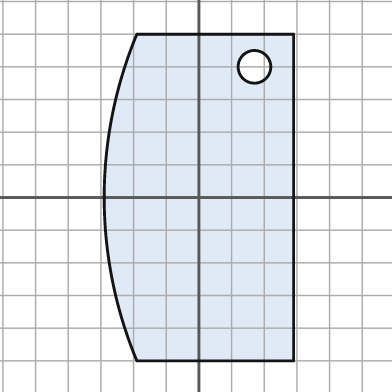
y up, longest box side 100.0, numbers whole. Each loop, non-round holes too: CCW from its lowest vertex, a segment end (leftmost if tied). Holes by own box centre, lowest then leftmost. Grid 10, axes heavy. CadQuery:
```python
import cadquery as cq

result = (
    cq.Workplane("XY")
    .moveTo(-19.0, -50.0)
    .lineTo(29.0, -50.0)
    .lineTo(29.0, 50.0)
    .lineTo(-19.0, 50.0)
    .threePointArc((-29.0, 0.0), (-19.0, -50.0))
    .close()
    .moveTo(17.0, 40.0)
    .circle(5.0)
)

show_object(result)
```